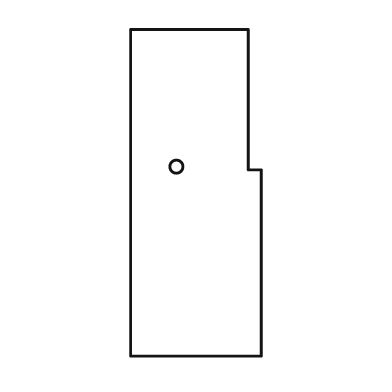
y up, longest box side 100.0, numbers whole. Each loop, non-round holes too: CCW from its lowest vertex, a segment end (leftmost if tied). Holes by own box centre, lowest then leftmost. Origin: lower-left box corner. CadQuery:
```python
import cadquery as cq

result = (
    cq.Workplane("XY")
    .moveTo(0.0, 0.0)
    .lineTo(40.0, 0.0)
    .lineTo(40.0, 57.0)
    .lineTo(36.0, 57.0)
    .lineTo(36.0, 100.0)
    .lineTo(0.0, 100.0)
    .close()
    .moveTo(14.0, 58.0)
    .circle(2.0)
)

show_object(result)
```